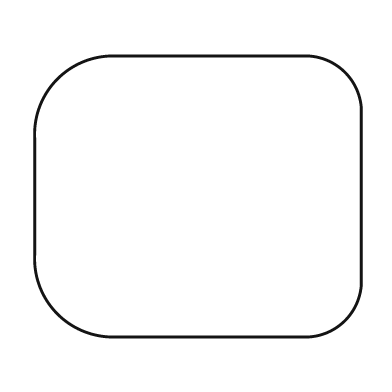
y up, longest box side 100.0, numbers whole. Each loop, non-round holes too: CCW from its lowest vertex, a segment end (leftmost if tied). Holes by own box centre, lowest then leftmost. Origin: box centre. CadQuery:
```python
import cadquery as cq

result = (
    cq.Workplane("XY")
    .moveTo(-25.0, -43.0)
    .lineTo(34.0, -43.0)
    .threePointArc((45.0, -38.0), (50.0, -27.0))
    .lineTo(50.0, 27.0)
    .threePointArc((45.0, 38.0), (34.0, 43.0))
    .lineTo(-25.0, 43.0)
    .threePointArc((-43.0, 36.0), (-50.0, 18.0))
    .lineTo(-50.0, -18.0)
    .threePointArc((-43.0, -36.0), (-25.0, -43.0))
    .close()
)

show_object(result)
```